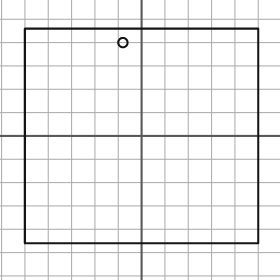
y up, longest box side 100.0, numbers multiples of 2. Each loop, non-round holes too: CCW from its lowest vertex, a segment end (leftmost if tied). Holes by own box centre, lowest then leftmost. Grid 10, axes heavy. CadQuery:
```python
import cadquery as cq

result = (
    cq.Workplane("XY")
    .moveTo(-50.0, -46.0)
    .lineTo(50.0, -46.0)
    .lineTo(50.0, 46.0)
    .lineTo(-50.0, 46.0)
    .close()
    .moveTo(-8.0, 40.0)
    .circle(2.0)
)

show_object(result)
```